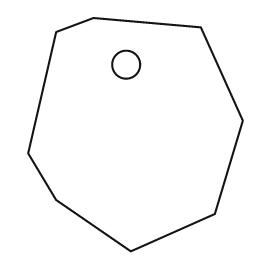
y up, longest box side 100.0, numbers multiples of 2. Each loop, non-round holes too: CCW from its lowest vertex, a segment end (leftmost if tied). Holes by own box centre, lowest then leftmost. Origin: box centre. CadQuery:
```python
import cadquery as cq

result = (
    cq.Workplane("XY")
    .moveTo(-2.0, -50.0)
    .lineTo(34.0, -34.0)
    .lineTo(46.0, 6.0)
    .lineTo(28.0, 46.0)
    .lineTo(-18.0, 50.0)
    .lineTo(-34.0, 44.0)
    .lineTo(-46.0, -8.0)
    .lineTo(-34.0, -28.0)
    .close()
    .moveTo(-4.0, 30.0)
    .circle(6.0)
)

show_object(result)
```